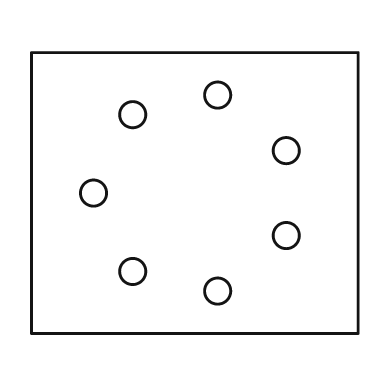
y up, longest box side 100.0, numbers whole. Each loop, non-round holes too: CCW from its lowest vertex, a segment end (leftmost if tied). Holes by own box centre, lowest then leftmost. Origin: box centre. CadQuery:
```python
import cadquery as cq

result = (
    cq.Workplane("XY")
    .moveTo(-50.0, -43.0)
    .lineTo(50.0, -43.0)
    .lineTo(50.0, 43.0)
    .lineTo(-50.0, 43.0)
    .close()
    .moveTo(7.0, -30.0)
    .circle(4.0)
    .moveTo(-19.0, -24.0)
    .circle(4.0)
    .moveTo(28.0, -13.0)
    .circle(4.0)
    .moveTo(-31.0, 0.0)
    .circle(4.0)
    .moveTo(28.0, 13.0)
    .circle(4.0)
    .moveTo(-19.0, 24.0)
    .circle(4.0)
    .moveTo(7.0, 30.0)
    .circle(4.0)
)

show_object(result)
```